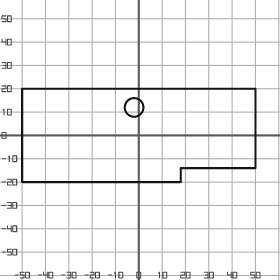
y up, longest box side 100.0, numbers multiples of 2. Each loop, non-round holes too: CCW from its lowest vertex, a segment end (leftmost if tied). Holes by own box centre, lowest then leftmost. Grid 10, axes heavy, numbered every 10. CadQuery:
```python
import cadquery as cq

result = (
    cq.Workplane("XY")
    .moveTo(-50.0, -20.0)
    .lineTo(18.0, -20.0)
    .lineTo(18.0, -14.0)
    .lineTo(50.0, -14.0)
    .lineTo(50.0, 20.0)
    .lineTo(-50.0, 20.0)
    .close()
    .moveTo(-2.0, 12.0)
    .circle(4.0)
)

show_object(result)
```